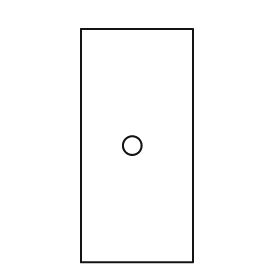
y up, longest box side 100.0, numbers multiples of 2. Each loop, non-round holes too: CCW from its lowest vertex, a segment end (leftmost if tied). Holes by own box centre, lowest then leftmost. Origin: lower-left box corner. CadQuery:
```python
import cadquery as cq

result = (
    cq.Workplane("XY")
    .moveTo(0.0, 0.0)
    .lineTo(48.0, 0.0)
    .lineTo(48.0, 100.0)
    .lineTo(0.0, 100.0)
    .close()
    .moveTo(22.0, 50.0)
    .circle(4.0)
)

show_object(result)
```